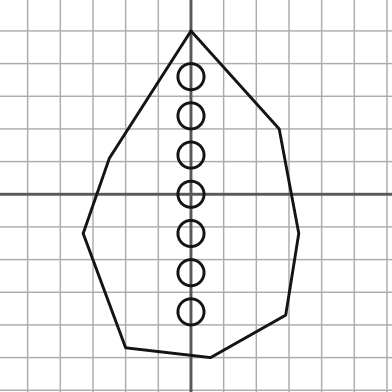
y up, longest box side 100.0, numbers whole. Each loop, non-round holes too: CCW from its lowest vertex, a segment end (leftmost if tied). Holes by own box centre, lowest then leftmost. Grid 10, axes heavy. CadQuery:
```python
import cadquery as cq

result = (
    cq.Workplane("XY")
    .moveTo(6.0, -50.0)
    .lineTo(29.0, -37.0)
    .lineTo(33.0, -12.0)
    .lineTo(27.0, 20.0)
    .lineTo(0.0, 50.0)
    .lineTo(-25.0, 11.0)
    .lineTo(-33.0, -12.0)
    .lineTo(-20.0, -47.0)
    .close()
    .moveTo(0.0, -36.0)
    .circle(4.0)
    .moveTo(0.0, -24.0)
    .circle(4.0)
    .moveTo(0.0, -12.0)
    .circle(4.0)
    .moveTo(0.0, 0.0)
    .circle(4.0)
    .moveTo(0.0, 12.0)
    .circle(4.0)
    .moveTo(0.0, 24.0)
    .circle(4.0)
    .moveTo(0.0, 36.0)
    .circle(4.0)
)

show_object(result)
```